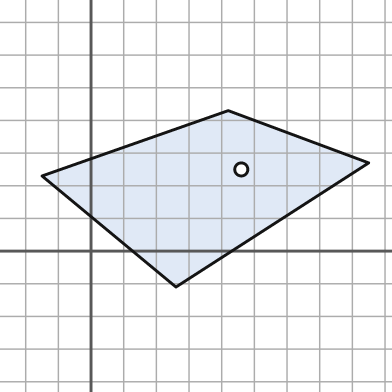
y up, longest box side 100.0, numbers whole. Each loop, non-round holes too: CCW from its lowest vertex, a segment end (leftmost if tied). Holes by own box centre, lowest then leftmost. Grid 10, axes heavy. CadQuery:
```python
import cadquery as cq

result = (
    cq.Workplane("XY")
    .moveTo(26.0, -11.0)
    .lineTo(85.0, 27.0)
    .lineTo(42.0, 43.0)
    .lineTo(-15.0, 23.0)
    .close()
    .moveTo(46.0, 25.0)
    .circle(2.0)
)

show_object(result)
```